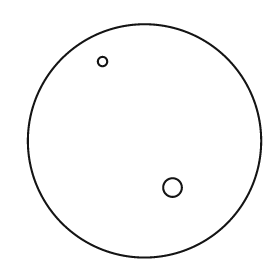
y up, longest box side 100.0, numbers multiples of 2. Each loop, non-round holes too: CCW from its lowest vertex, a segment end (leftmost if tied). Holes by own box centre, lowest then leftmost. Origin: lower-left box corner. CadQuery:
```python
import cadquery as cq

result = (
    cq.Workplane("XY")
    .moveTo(50.0, 50.0)
    .circle(50.0)
    .moveTo(62.0, 30.0)
    .circle(4.0)
    .moveTo(32.0, 84.0)
    .circle(2.0)
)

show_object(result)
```